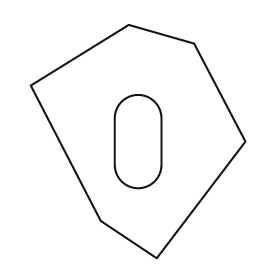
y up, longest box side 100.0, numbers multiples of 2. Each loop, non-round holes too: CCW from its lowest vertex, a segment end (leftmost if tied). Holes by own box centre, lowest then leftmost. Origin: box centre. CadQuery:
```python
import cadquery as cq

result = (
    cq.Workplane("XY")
    .moveTo(8.0, -50.0)
    .lineTo(46.0, 0.0)
    .lineTo(24.0, 42.0)
    .lineTo(-4.0, 50.0)
    .lineTo(-46.0, 24.0)
    .lineTo(-16.0, -34.0)
    .close()
    .moveTo(-10.0, -10.0)
    .threePointArc((0.0, -20.0), (10.0, -10.0))
    .lineTo(10.0, 10.0)
    .threePointArc((0.0, 20.0), (-10.0, 10.0))
    .close()
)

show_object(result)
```